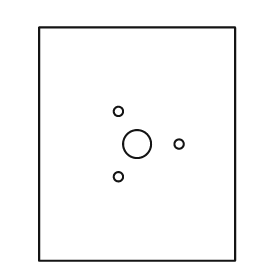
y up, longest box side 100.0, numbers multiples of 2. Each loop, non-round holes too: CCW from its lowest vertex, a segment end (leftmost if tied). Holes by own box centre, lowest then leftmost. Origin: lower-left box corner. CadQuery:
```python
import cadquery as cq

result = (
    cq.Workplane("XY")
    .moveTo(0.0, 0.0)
    .lineTo(84.0, 0.0)
    .lineTo(84.0, 100.0)
    .lineTo(0.0, 100.0)
    .close()
    .moveTo(34.0, 36.0)
    .circle(2.0)
    .moveTo(42.0, 50.0)
    .circle(6.0)
    .moveTo(60.0, 50.0)
    .circle(2.0)
    .moveTo(34.0, 64.0)
    .circle(2.0)
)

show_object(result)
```